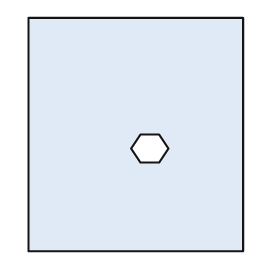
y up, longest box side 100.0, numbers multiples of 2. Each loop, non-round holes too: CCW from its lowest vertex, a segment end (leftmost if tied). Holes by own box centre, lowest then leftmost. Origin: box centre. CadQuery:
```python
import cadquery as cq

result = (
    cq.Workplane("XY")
    .moveTo(-46.0, -50.0)
    .lineTo(46.0, -50.0)
    .lineTo(46.0, 50.0)
    .lineTo(-46.0, 50.0)
    .close()
    .moveTo(2.0, -12.0)
    .lineTo(10.0, -12.0)
    .lineTo(14.0, -6.0)
    .lineTo(10.0, 0.0)
    .lineTo(2.0, 0.0)
    .lineTo(-2.0, -6.0)
    .close()
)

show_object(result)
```